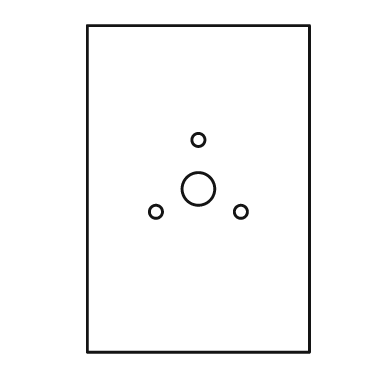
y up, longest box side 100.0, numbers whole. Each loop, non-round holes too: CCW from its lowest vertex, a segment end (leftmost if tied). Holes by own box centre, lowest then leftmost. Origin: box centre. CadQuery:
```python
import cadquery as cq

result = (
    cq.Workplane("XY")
    .moveTo(-34.0, -50.0)
    .lineTo(34.0, -50.0)
    .lineTo(34.0, 50.0)
    .lineTo(-34.0, 50.0)
    .close()
    .moveTo(-13.0, -7.0)
    .circle(2.0)
    .moveTo(13.0, -7.0)
    .circle(2.0)
    .moveTo(0.0, 0.0)
    .circle(5.0)
    .moveTo(0.0, 15.0)
    .circle(2.0)
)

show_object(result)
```